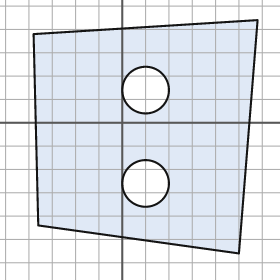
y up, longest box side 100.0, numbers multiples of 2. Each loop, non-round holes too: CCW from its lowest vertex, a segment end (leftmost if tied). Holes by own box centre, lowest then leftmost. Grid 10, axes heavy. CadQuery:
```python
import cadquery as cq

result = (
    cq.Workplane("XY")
    .moveTo(50.0, -56.0)
    .lineTo(58.0, 44.0)
    .lineTo(-38.0, 38.0)
    .lineTo(-36.0, -44.0)
    .close()
    .moveTo(10.0, -26.0)
    .circle(10.0)
    .moveTo(10.0, 14.0)
    .circle(10.0)
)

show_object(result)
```